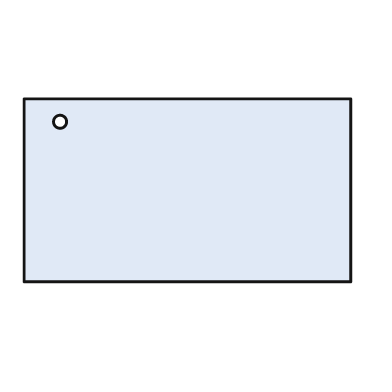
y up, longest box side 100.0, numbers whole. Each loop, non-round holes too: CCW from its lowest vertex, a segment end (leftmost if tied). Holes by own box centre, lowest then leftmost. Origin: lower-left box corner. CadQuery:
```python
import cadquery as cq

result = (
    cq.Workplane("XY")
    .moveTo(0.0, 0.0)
    .lineTo(100.0, 0.0)
    .lineTo(100.0, 56.0)
    .lineTo(0.0, 56.0)
    .close()
    .moveTo(11.0, 49.0)
    .circle(2.0)
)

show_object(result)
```